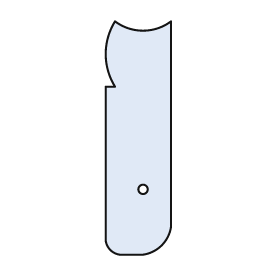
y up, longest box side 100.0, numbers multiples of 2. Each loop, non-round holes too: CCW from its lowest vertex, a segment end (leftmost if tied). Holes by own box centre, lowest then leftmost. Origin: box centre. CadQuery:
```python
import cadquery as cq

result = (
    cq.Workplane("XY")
    .moveTo(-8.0, -50.0)
    .lineTo(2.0, -50.0)
    .threePointArc((10.0, -46.0), (14.0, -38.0))
    .lineTo(14.0, 50.0)
    .threePointArc((2.0, 46.0), (-10.0, 50.0))
    .threePointArc((-14.0, 36.0), (-10.0, 22.0))
    .lineTo(-14.0, 22.0)
    .lineTo(-14.0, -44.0)
    .threePointArc((-12.0, -48.0), (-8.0, -50.0))
    .close()
    .moveTo(2.0, -22.0)
    .circle(2.0)
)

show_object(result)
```